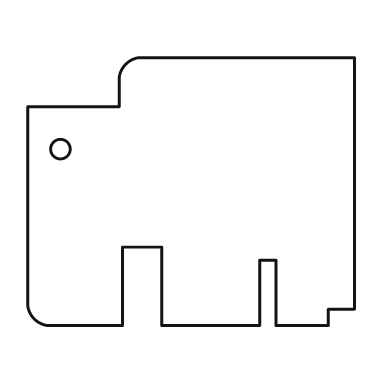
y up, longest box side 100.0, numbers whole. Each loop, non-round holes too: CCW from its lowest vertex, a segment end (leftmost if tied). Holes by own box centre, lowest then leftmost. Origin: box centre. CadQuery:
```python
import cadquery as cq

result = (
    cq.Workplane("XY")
    .moveTo(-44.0, -41.0)
    .lineTo(-21.0, -41.0)
    .lineTo(-21.0, -17.0)
    .lineTo(-9.0, -17.0)
    .lineTo(-9.0, -41.0)
    .lineTo(21.0, -41.0)
    .lineTo(21.0, -21.0)
    .lineTo(26.0, -21.0)
    .lineTo(26.0, -41.0)
    .lineTo(42.0, -41.0)
    .lineTo(42.0, -36.0)
    .lineTo(50.0, -36.0)
    .lineTo(50.0, 41.0)
    .lineTo(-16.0, 41.0)
    .threePointArc((-20.0, 39.0), (-22.0, 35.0))
    .lineTo(-22.0, 26.0)
    .lineTo(-50.0, 26.0)
    .lineTo(-50.0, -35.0)
    .threePointArc((-48.0, -39.0), (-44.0, -41.0))
    .close()
    .moveTo(-40.0, 13.0)
    .circle(3.0)
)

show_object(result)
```